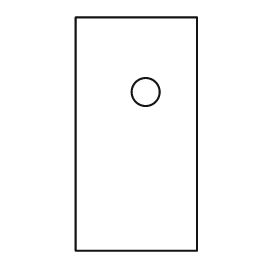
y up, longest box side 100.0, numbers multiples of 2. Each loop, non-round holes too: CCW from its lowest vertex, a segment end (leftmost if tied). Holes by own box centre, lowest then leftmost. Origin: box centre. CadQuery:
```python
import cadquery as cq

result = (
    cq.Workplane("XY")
    .moveTo(-26.0, -50.0)
    .lineTo(26.0, -50.0)
    .lineTo(26.0, 50.0)
    .lineTo(-26.0, 50.0)
    .close()
    .moveTo(4.0, 18.0)
    .circle(6.0)
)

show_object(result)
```